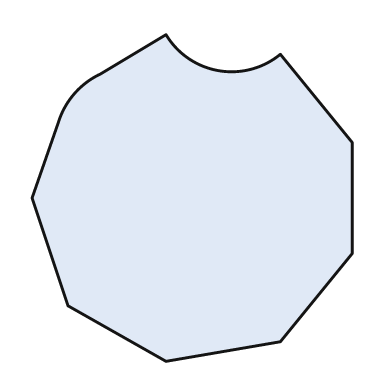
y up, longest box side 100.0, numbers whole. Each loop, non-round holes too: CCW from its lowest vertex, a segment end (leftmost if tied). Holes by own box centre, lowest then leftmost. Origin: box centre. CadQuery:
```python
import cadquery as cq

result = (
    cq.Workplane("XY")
    .moveTo(-8.0, -50.0)
    .lineTo(27.0, -44.0)
    .lineTo(49.0, -17.0)
    .lineTo(49.0, 17.0)
    .lineTo(27.0, 44.0)
    .threePointArc((8.0, 39.0), (-8.0, 50.0))
    .lineTo(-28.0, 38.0)
    .threePointArc((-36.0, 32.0), (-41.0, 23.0))
    .lineTo(-49.0, 0.0)
    .lineTo(-38.0, -33.0)
    .close()
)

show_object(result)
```